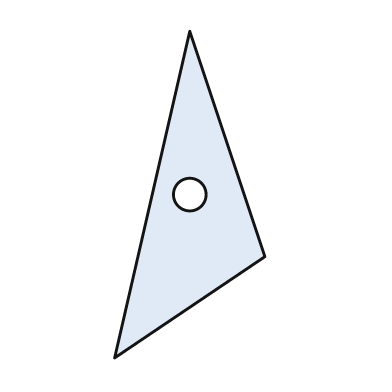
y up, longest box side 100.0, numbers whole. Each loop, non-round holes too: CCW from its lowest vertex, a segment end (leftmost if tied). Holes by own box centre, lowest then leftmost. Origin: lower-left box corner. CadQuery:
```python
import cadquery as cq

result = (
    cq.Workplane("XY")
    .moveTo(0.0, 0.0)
    .lineTo(46.0, 31.0)
    .lineTo(23.0, 100.0)
    .close()
    .moveTo(23.0, 50.0)
    .circle(5.0)
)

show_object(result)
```